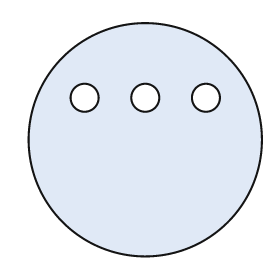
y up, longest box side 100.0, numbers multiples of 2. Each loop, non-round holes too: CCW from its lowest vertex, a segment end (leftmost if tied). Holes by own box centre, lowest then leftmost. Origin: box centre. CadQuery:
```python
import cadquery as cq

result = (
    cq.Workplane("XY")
    .moveTo(0.0, 0.0)
    .circle(50.0)
    .moveTo(-26.0, 18.0)
    .circle(6.0)
    .moveTo(0.0, 18.0)
    .circle(6.0)
    .moveTo(26.0, 18.0)
    .circle(6.0)
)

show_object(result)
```